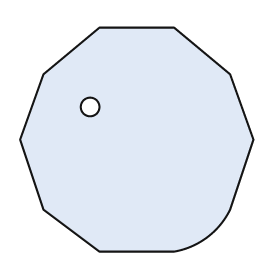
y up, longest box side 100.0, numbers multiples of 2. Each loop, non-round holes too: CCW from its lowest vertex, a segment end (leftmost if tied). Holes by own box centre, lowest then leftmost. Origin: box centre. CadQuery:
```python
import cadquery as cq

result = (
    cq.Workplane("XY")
    .moveTo(-16.0, -48.0)
    .lineTo(16.0, -48.0)
    .threePointArc((30.0, -42.0), (40.0, -30.0))
    .lineTo(50.0, 0.0)
    .lineTo(40.0, 28.0)
    .lineTo(16.0, 48.0)
    .lineTo(-16.0, 48.0)
    .lineTo(-40.0, 28.0)
    .lineTo(-50.0, 0.0)
    .lineTo(-40.0, -30.0)
    .close()
    .moveTo(-20.0, 14.0)
    .circle(4.0)
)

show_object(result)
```